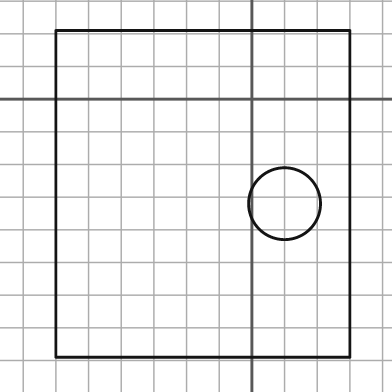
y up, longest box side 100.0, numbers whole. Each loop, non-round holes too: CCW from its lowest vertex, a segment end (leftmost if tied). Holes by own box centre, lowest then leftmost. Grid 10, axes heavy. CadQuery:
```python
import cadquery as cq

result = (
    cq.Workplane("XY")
    .moveTo(-60.0, -79.0)
    .lineTo(30.0, -79.0)
    .lineTo(30.0, 21.0)
    .lineTo(-60.0, 21.0)
    .close()
    .moveTo(10.0, -32.0)
    .circle(11.0)
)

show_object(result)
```